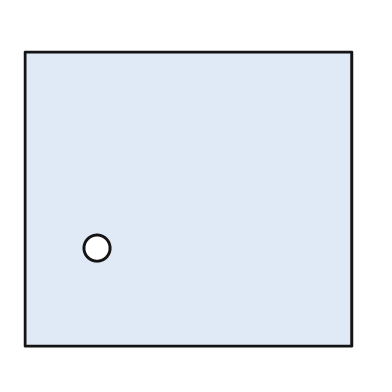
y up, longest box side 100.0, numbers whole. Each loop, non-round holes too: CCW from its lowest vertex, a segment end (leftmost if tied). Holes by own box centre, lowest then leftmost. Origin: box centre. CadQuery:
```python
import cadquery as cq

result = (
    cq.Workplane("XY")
    .moveTo(-50.0, -45.0)
    .lineTo(50.0, -45.0)
    .lineTo(50.0, 45.0)
    .lineTo(-50.0, 45.0)
    .close()
    .moveTo(-28.0, -15.0)
    .circle(4.0)
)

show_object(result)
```